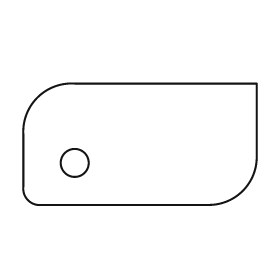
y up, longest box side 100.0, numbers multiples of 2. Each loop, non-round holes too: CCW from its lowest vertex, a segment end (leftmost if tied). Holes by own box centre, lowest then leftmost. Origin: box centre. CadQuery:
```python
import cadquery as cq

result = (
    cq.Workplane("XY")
    .moveTo(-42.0, -26.0)
    .lineTo(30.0, -26.0)
    .threePointArc((44.0, -20.0), (50.0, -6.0))
    .lineTo(50.0, 26.0)
    .lineTo(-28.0, 26.0)
    .threePointArc((-44.0, 20.0), (-50.0, 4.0))
    .lineTo(-50.0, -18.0)
    .threePointArc((-48.0, -24.0), (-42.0, -26.0))
    .close()
    .moveTo(-28.0, -8.0)
    .circle(6.0)
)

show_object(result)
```